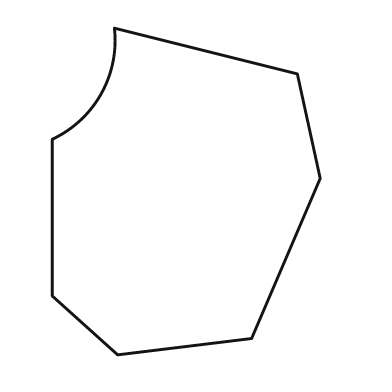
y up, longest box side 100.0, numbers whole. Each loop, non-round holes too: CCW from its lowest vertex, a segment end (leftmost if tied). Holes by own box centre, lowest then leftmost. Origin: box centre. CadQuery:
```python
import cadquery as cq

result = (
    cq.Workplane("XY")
    .moveTo(-21.0, -50.0)
    .lineTo(20.0, -45.0)
    .lineTo(41.0, 4.0)
    .lineTo(34.0, 36.0)
    .lineTo(-22.0, 50.0)
    .threePointArc((-26.0, 30.0), (-41.0, 16.0))
    .lineTo(-41.0, -32.0)
    .close()
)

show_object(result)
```